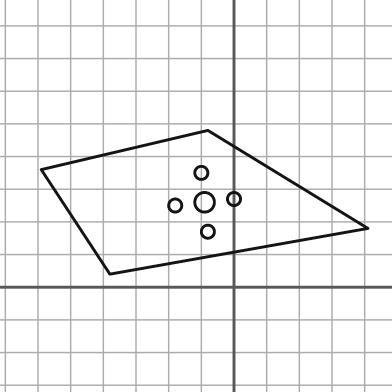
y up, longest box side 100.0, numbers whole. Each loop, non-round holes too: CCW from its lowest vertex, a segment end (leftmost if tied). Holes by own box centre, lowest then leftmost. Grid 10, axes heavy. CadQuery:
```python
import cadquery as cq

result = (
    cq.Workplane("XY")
    .moveTo(-38.0, 4.0)
    .lineTo(41.0, 18.0)
    .lineTo(-8.0, 48.0)
    .lineTo(-59.0, 36.0)
    .close()
    .moveTo(-8.0, 17.0)
    .circle(2.0)
    .moveTo(-18.0, 25.0)
    .circle(2.0)
    .moveTo(-9.0, 26.0)
    .circle(3.0)
    .moveTo(0.0, 27.0)
    .circle(2.0)
    .moveTo(-10.0, 35.0)
    .circle(2.0)
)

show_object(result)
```